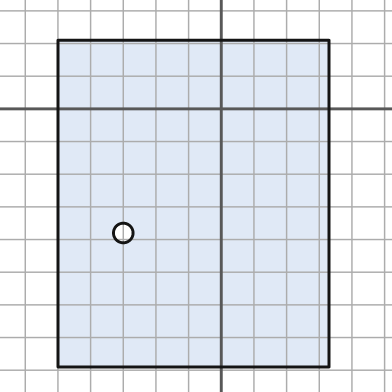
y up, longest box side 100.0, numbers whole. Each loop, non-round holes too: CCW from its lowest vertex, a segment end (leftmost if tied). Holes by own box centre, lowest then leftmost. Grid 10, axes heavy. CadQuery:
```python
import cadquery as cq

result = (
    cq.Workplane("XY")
    .moveTo(-50.0, -79.0)
    .lineTo(33.0, -79.0)
    .lineTo(33.0, 21.0)
    .lineTo(-50.0, 21.0)
    .close()
    .moveTo(-30.0, -38.0)
    .circle(3.0)
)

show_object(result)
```